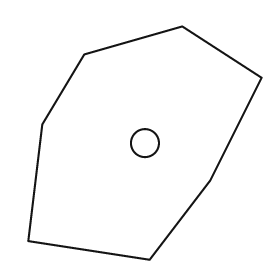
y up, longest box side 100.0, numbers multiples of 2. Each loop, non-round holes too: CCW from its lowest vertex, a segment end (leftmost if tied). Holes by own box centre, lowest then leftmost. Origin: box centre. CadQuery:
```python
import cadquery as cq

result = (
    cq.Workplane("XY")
    .moveTo(2.0, -50.0)
    .lineTo(28.0, -16.0)
    .lineTo(50.0, 28.0)
    .lineTo(16.0, 50.0)
    .lineTo(-26.0, 38.0)
    .lineTo(-44.0, 8.0)
    .lineTo(-50.0, -42.0)
    .close()
    .moveTo(0.0, 0.0)
    .circle(6.0)
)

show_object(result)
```